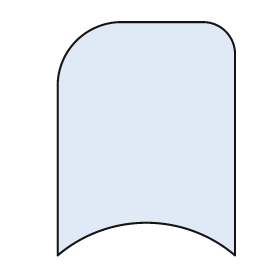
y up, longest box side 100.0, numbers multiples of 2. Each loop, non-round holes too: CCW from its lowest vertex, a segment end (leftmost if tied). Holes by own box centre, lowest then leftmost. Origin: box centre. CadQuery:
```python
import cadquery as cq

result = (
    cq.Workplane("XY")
    .moveTo(-38.0, -50.0)
    .threePointArc((0.0, -36.0), (38.0, -50.0))
    .lineTo(38.0, 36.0)
    .threePointArc((34.0, 46.0), (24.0, 50.0))
    .lineTo(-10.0, 50.0)
    .threePointArc((-30.0, 42.0), (-38.0, 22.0))
    .close()
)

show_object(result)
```